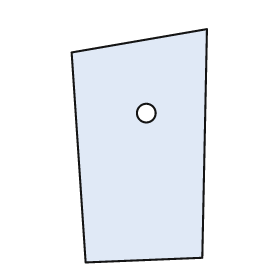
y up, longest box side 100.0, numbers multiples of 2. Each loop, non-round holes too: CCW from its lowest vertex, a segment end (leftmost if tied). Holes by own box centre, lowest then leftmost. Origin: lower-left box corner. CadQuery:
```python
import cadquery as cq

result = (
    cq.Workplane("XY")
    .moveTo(6.0, 0.0)
    .lineTo(56.0, 2.0)
    .lineTo(58.0, 100.0)
    .lineTo(0.0, 90.0)
    .close()
    .moveTo(32.0, 64.0)
    .circle(4.0)
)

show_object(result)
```